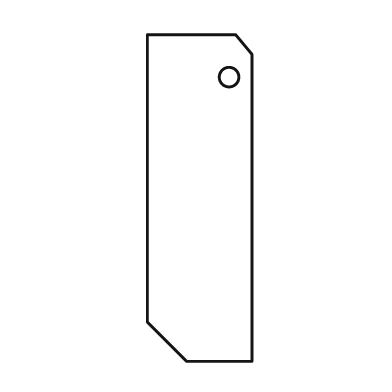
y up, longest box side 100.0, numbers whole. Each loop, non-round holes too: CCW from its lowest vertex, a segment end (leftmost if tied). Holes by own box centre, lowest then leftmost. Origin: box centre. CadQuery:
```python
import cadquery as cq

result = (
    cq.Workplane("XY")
    .moveTo(-4.0, -50.0)
    .lineTo(16.0, -50.0)
    .lineTo(16.0, 44.0)
    .lineTo(11.0, 50.0)
    .lineTo(-16.0, 50.0)
    .lineTo(-16.0, -38.0)
    .close()
    .moveTo(9.0, 37.0)
    .circle(3.0)
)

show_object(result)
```